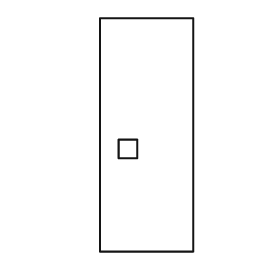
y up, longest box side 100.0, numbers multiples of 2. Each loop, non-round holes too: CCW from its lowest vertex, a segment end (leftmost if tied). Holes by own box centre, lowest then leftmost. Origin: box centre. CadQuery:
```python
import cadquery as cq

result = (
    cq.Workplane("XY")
    .moveTo(-20.0, -50.0)
    .lineTo(20.0, -50.0)
    .lineTo(20.0, 50.0)
    .lineTo(-20.0, 50.0)
    .close()
    .moveTo(-12.0, -10.0)
    .lineTo(-4.0, -10.0)
    .lineTo(-4.0, -2.0)
    .lineTo(-12.0, -2.0)
    .close()
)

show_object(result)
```